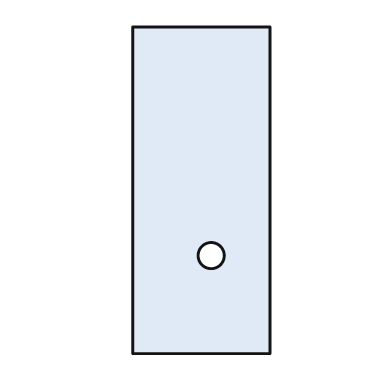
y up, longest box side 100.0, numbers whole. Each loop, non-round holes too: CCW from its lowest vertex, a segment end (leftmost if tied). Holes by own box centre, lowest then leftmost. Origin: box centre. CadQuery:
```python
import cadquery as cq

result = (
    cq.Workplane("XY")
    .moveTo(-21.0, -50.0)
    .lineTo(21.0, -50.0)
    .lineTo(21.0, 50.0)
    .lineTo(-21.0, 50.0)
    .close()
    .moveTo(3.0, -20.0)
    .circle(4.0)
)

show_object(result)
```